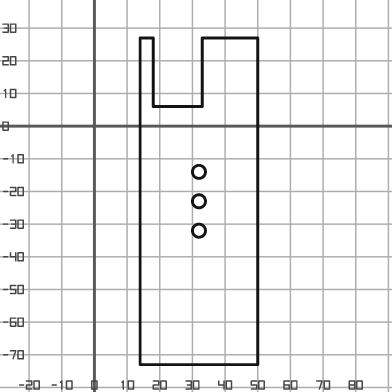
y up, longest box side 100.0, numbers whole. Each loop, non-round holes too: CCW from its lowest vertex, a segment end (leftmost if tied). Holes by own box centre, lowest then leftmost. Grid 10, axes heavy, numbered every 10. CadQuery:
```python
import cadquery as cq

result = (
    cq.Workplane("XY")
    .moveTo(14.0, -73.0)
    .lineTo(50.0, -73.0)
    .lineTo(50.0, 27.0)
    .lineTo(33.0, 27.0)
    .lineTo(33.0, 6.0)
    .lineTo(18.0, 6.0)
    .lineTo(18.0, 27.0)
    .lineTo(14.0, 27.0)
    .close()
    .moveTo(32.0, -32.0)
    .circle(2.0)
    .moveTo(32.0, -23.0)
    .circle(2.0)
    .moveTo(32.0, -14.0)
    .circle(2.0)
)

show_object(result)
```